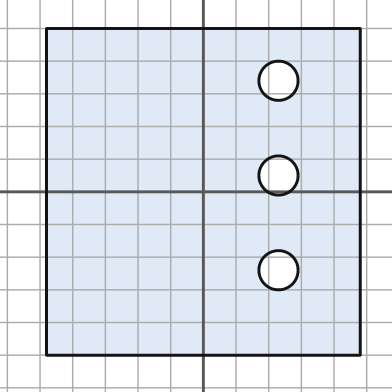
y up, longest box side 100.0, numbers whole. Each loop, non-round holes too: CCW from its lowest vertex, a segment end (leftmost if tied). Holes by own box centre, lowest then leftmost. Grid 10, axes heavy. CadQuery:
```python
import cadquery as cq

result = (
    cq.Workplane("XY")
    .moveTo(-48.0, -50.0)
    .lineTo(48.0, -50.0)
    .lineTo(48.0, 50.0)
    .lineTo(-48.0, 50.0)
    .close()
    .moveTo(23.0, -24.0)
    .circle(6.0)
    .moveTo(23.0, 5.0)
    .circle(6.0)
    .moveTo(23.0, 34.0)
    .circle(6.0)
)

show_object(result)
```